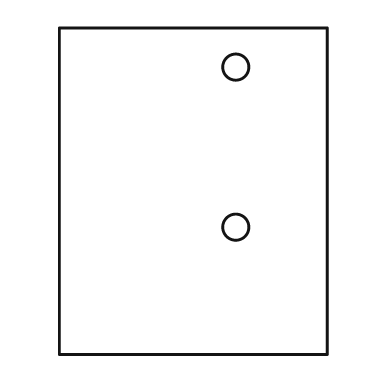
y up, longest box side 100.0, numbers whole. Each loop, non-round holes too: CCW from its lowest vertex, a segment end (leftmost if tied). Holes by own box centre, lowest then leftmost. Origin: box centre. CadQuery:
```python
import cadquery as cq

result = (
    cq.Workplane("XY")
    .moveTo(-41.0, -50.0)
    .lineTo(41.0, -50.0)
    .lineTo(41.0, 50.0)
    .lineTo(-41.0, 50.0)
    .close()
    .moveTo(13.0, -11.0)
    .circle(4.0)
    .moveTo(13.0, 38.0)
    .circle(4.0)
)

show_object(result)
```